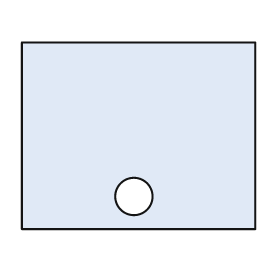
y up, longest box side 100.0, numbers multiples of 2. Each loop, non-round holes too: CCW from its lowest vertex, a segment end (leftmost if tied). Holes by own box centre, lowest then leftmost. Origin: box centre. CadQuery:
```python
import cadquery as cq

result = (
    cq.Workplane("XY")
    .moveTo(-50.0, -40.0)
    .lineTo(50.0, -40.0)
    .lineTo(50.0, 40.0)
    .lineTo(-50.0, 40.0)
    .close()
    .moveTo(-2.0, -26.0)
    .circle(8.0)
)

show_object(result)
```